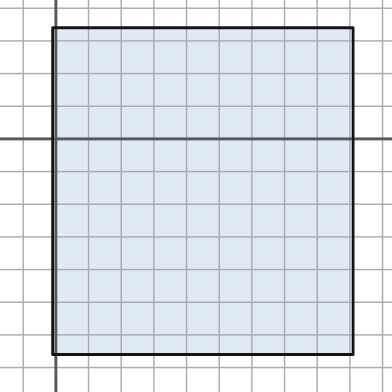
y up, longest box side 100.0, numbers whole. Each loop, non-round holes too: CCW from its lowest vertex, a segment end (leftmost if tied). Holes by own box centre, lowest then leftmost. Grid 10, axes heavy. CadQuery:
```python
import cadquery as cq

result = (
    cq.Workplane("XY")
    .moveTo(-1.0, -66.0)
    .lineTo(91.0, -66.0)
    .lineTo(91.0, 34.0)
    .lineTo(-1.0, 34.0)
    .close()
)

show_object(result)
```